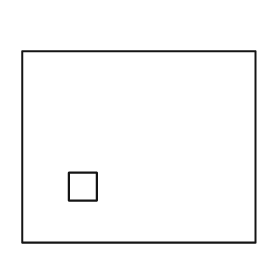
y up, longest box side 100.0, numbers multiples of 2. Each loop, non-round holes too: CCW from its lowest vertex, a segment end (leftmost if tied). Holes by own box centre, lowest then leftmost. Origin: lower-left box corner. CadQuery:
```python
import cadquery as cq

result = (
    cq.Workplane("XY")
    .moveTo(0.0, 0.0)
    .lineTo(100.0, 0.0)
    .lineTo(100.0, 82.0)
    .lineTo(0.0, 82.0)
    .close()
    .moveTo(20.0, 18.0)
    .lineTo(32.0, 18.0)
    .lineTo(32.0, 30.0)
    .lineTo(20.0, 30.0)
    .close()
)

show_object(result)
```